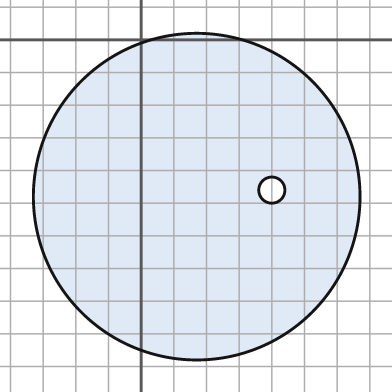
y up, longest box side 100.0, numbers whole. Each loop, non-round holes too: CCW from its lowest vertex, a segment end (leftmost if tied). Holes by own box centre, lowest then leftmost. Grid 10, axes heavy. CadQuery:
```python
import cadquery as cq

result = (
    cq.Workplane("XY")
    .moveTo(17.0, -48.0)
    .circle(50.0)
    .moveTo(40.0, -46.0)
    .circle(4.0)
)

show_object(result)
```